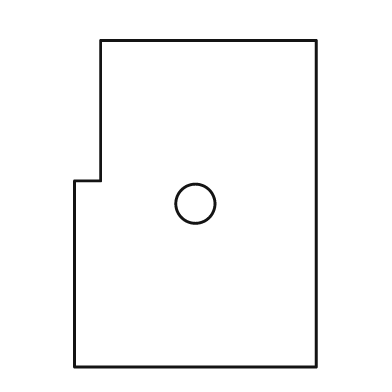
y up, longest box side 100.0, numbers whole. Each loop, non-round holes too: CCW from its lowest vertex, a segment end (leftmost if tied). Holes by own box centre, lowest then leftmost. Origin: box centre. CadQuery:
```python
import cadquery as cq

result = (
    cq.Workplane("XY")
    .moveTo(-37.0, -50.0)
    .lineTo(37.0, -50.0)
    .lineTo(37.0, 50.0)
    .lineTo(-29.0, 50.0)
    .lineTo(-29.0, 7.0)
    .lineTo(-37.0, 7.0)
    .close()
    .moveTo(0.0, 0.0)
    .circle(6.0)
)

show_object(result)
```